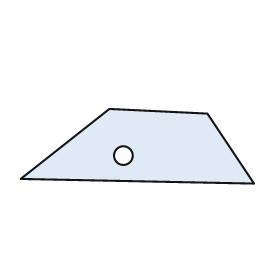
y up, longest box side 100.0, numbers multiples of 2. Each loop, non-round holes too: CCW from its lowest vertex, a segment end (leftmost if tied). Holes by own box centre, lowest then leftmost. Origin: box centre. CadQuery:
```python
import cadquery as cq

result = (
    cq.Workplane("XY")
    .moveTo(50.0, -16.0)
    .lineTo(30.0, 14.0)
    .lineTo(-12.0, 16.0)
    .lineTo(-50.0, -14.0)
    .close()
    .moveTo(-6.0, -4.0)
    .circle(4.0)
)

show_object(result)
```